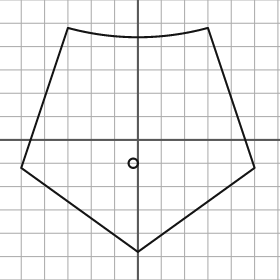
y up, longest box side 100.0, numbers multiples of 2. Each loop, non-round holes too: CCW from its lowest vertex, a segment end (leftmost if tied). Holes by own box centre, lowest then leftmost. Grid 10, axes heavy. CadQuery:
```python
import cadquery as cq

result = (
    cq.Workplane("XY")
    .moveTo(0.0, -48.0)
    .lineTo(50.0, -12.0)
    .lineTo(30.0, 48.0)
    .threePointArc((0.0, 44.0), (-30.0, 48.0))
    .lineTo(-50.0, -12.0)
    .close()
    .moveTo(-2.0, -10.0)
    .circle(2.0)
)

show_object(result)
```